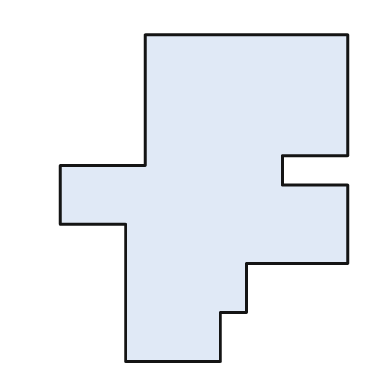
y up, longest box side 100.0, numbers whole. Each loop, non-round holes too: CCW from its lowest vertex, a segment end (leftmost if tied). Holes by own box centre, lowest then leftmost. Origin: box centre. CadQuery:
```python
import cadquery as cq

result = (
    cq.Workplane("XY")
    .moveTo(-24.0, -50.0)
    .lineTo(5.0, -50.0)
    .lineTo(5.0, -35.0)
    .lineTo(13.0, -35.0)
    .lineTo(13.0, -20.0)
    .lineTo(44.0, -20.0)
    .lineTo(44.0, 4.0)
    .lineTo(24.0, 4.0)
    .lineTo(24.0, 13.0)
    .lineTo(44.0, 13.0)
    .lineTo(44.0, 50.0)
    .lineTo(-18.0, 50.0)
    .lineTo(-18.0, 10.0)
    .lineTo(-44.0, 10.0)
    .lineTo(-44.0, -8.0)
    .lineTo(-24.0, -8.0)
    .close()
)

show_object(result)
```